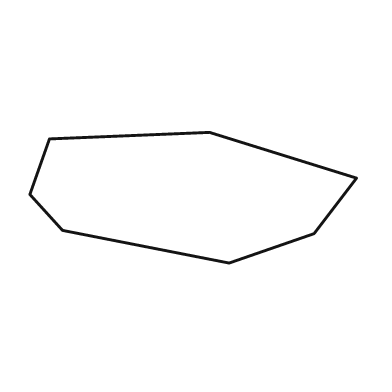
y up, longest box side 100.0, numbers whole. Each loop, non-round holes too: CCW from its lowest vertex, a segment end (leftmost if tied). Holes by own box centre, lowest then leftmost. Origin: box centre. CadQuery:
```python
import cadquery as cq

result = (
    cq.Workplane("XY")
    .moveTo(11.0, -20.0)
    .lineTo(37.0, -11.0)
    .lineTo(50.0, 6.0)
    .lineTo(5.0, 20.0)
    .lineTo(-44.0, 18.0)
    .lineTo(-50.0, 1.0)
    .lineTo(-40.0, -10.0)
    .close()
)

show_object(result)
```